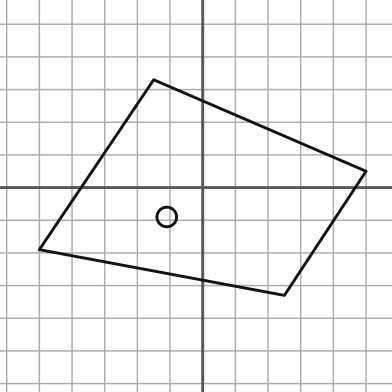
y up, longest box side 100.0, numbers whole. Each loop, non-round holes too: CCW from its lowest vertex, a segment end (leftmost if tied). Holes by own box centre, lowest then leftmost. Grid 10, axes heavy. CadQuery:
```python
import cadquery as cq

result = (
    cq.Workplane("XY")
    .moveTo(25.0, -33.0)
    .lineTo(50.0, 5.0)
    .lineTo(-15.0, 33.0)
    .lineTo(-50.0, -19.0)
    .close()
    .moveTo(-11.0, -9.0)
    .circle(3.0)
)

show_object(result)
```